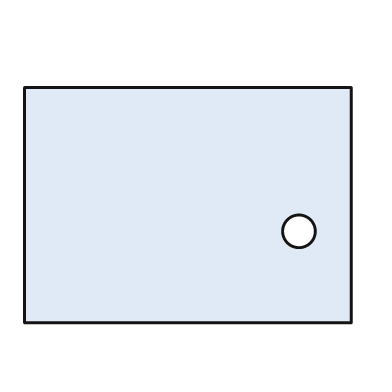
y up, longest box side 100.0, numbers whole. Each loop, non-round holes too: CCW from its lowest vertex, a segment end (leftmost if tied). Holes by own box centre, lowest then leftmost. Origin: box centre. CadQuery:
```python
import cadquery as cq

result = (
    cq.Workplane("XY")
    .moveTo(-50.0, -36.0)
    .lineTo(50.0, -36.0)
    .lineTo(50.0, 36.0)
    .lineTo(-50.0, 36.0)
    .close()
    .moveTo(34.0, -8.0)
    .circle(5.0)
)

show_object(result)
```